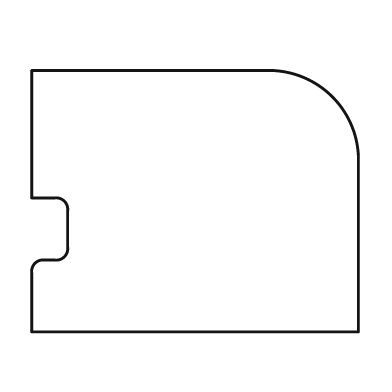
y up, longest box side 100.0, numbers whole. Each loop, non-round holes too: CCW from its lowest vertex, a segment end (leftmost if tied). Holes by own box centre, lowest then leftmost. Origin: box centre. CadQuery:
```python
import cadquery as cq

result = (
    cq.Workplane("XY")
    .moveTo(-50.0, -40.0)
    .lineTo(50.0, -40.0)
    .lineTo(50.0, 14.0)
    .threePointArc((42.0, 32.0), (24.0, 40.0))
    .lineTo(-50.0, 40.0)
    .lineTo(-50.0, 1.0)
    .lineTo(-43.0, 1.0)
    .threePointArc((-40.0, 0.0), (-39.0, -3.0))
    .lineTo(-39.0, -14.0)
    .threePointArc((-40.0, -17.0), (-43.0, -18.0))
    .lineTo(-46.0, -18.0)
    .threePointArc((-49.0, -19.0), (-50.0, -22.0))
    .close()
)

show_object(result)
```